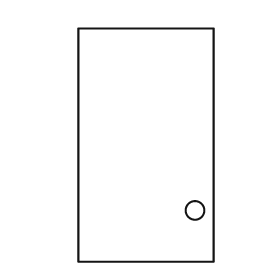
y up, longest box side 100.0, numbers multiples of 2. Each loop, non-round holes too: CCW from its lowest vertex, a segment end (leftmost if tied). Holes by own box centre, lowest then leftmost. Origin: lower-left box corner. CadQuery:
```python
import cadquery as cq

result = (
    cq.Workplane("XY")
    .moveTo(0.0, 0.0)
    .lineTo(58.0, 0.0)
    .lineTo(58.0, 100.0)
    .lineTo(0.0, 100.0)
    .close()
    .moveTo(50.0, 22.0)
    .circle(4.0)
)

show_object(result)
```